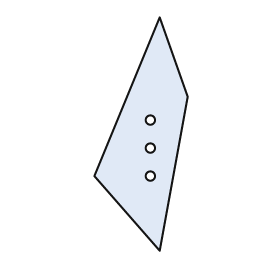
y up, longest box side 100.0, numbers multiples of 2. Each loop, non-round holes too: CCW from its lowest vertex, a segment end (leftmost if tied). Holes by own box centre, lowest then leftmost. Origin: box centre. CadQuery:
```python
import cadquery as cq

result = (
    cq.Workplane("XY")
    .moveTo(8.0, -50.0)
    .lineTo(20.0, 16.0)
    .lineTo(8.0, 50.0)
    .lineTo(-20.0, -18.0)
    .close()
    .moveTo(4.0, -18.0)
    .circle(2.0)
    .moveTo(4.0, -6.0)
    .circle(2.0)
    .moveTo(4.0, 6.0)
    .circle(2.0)
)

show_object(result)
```